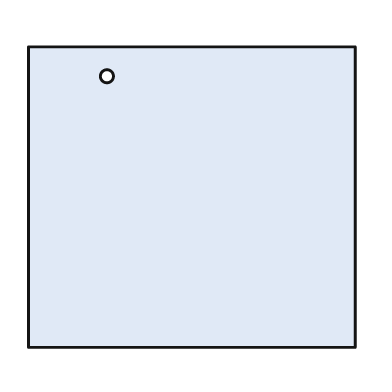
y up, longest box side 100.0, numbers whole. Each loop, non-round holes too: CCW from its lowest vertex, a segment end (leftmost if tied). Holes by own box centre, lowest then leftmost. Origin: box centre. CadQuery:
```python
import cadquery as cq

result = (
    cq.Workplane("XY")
    .moveTo(-50.0, -46.0)
    .lineTo(50.0, -46.0)
    .lineTo(50.0, 46.0)
    .lineTo(-50.0, 46.0)
    .close()
    .moveTo(-26.0, 37.0)
    .circle(2.0)
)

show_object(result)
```